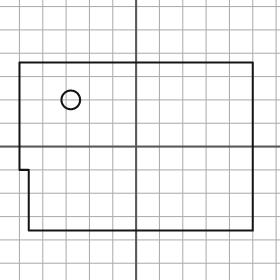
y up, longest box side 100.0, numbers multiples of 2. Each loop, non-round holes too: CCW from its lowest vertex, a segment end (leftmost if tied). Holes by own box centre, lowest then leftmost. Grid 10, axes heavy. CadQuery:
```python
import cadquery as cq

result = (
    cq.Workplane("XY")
    .moveTo(-46.0, -36.0)
    .lineTo(50.0, -36.0)
    .lineTo(50.0, 36.0)
    .lineTo(-50.0, 36.0)
    .lineTo(-50.0, -10.0)
    .lineTo(-46.0, -10.0)
    .close()
    .moveTo(-28.0, 20.0)
    .circle(4.0)
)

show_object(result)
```